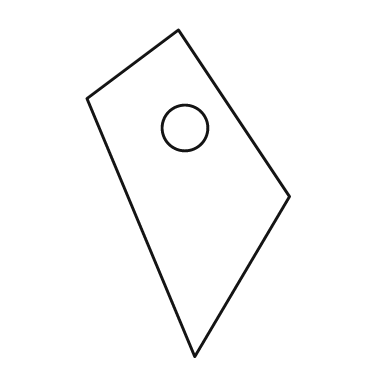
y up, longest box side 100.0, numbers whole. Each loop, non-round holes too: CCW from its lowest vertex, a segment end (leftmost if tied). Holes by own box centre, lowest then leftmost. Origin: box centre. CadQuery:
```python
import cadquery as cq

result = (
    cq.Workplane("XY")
    .moveTo(2.0, -50.0)
    .lineTo(31.0, -1.0)
    .lineTo(-3.0, 50.0)
    .lineTo(-31.0, 29.0)
    .close()
    .moveTo(-1.0, 20.0)
    .circle(7.0)
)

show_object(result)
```